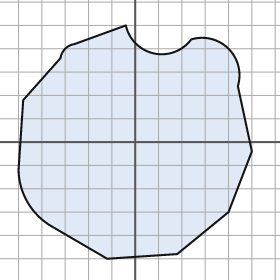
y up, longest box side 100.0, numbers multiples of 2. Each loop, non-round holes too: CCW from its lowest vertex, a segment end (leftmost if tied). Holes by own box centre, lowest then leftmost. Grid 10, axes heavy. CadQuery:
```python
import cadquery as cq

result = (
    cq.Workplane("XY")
    .moveTo(-12.0, -50.0)
    .lineTo(18.0, -48.0)
    .lineTo(40.0, -30.0)
    .lineTo(50.0, -4.0)
    .lineTo(44.0, 24.0)
    .threePointArc((40.0, 40.0), (24.0, 44.0))
    .threePointArc((8.0, 38.0), (-4.0, 50.0))
    .lineTo(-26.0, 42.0)
    .threePointArc((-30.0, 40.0), (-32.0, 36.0))
    .lineTo(-48.0, 18.0)
    .lineTo(-50.0, -12.0)
    .threePointArc((-46.0, -26.0), (-36.0, -36.0))
    .close()
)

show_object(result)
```